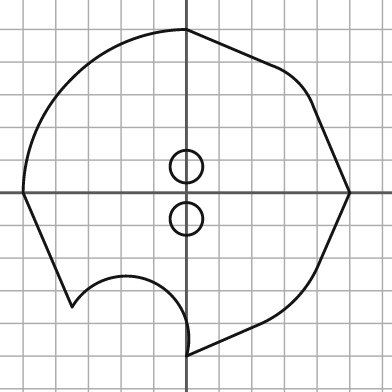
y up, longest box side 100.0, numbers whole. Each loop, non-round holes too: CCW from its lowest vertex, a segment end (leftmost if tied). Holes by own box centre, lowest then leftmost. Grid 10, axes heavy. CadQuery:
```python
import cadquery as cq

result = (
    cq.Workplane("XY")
    .moveTo(0.0, -50.0)
    .lineTo(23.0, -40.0)
    .threePointArc((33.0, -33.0), (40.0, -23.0))
    .lineTo(50.0, 0.0)
    .lineTo(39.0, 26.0)
    .threePointArc((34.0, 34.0), (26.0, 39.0))
    .lineTo(0.0, 50.0)
    .threePointArc((-19.0, 46.0), (-35.0, 35.0))
    .threePointArc((-46.0, 19.0), (-50.0, 0.0))
    .lineTo(-35.0, -35.0)
    .threePointArc((-11.0, -27.0), (0.0, -50.0))
    .close()
    .moveTo(0.0, -8.0)
    .circle(5.0)
    .moveTo(0.0, 8.0)
    .circle(5.0)
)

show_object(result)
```